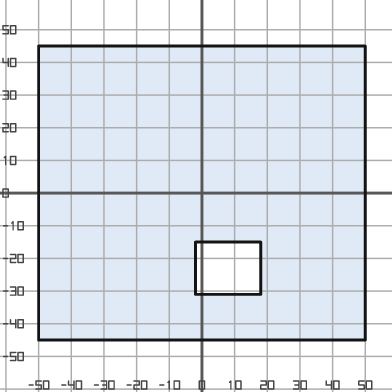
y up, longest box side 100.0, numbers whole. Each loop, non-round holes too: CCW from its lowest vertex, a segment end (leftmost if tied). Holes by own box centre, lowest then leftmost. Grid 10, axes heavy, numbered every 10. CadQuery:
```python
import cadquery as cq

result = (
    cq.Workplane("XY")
    .moveTo(-50.0, -45.0)
    .lineTo(50.0, -45.0)
    .lineTo(50.0, 45.0)
    .lineTo(-50.0, 45.0)
    .close()
    .moveTo(-2.0, -31.0)
    .lineTo(18.0, -31.0)
    .lineTo(18.0, -15.0)
    .lineTo(-2.0, -15.0)
    .close()
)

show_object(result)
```